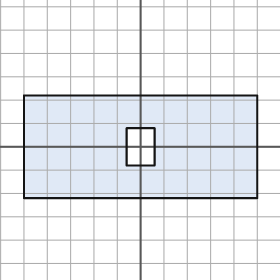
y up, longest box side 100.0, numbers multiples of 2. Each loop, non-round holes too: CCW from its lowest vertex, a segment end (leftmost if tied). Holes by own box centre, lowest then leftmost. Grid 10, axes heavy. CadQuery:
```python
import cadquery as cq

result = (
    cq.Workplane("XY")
    .moveTo(-50.0, -22.0)
    .lineTo(50.0, -22.0)
    .lineTo(50.0, 22.0)
    .lineTo(-50.0, 22.0)
    .close()
    .moveTo(-6.0, -8.0)
    .lineTo(6.0, -8.0)
    .lineTo(6.0, 8.0)
    .lineTo(-6.0, 8.0)
    .close()
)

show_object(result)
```